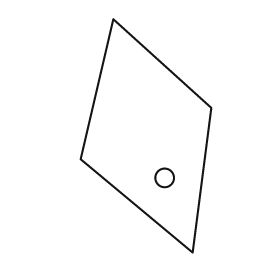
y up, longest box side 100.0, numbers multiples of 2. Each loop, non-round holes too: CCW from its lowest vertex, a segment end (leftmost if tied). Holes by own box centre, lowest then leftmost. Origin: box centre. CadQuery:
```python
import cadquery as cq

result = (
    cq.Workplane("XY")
    .moveTo(20.0, -50.0)
    .lineTo(28.0, 12.0)
    .lineTo(-14.0, 50.0)
    .lineTo(-28.0, -10.0)
    .close()
    .moveTo(8.0, -18.0)
    .circle(4.0)
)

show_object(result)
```